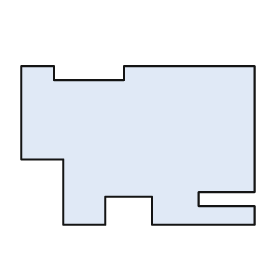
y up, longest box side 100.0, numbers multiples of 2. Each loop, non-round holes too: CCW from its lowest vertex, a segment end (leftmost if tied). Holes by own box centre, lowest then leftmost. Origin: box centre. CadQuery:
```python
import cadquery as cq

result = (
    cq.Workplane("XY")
    .moveTo(-32.0, -34.0)
    .lineTo(-14.0, -34.0)
    .lineTo(-14.0, -22.0)
    .lineTo(6.0, -22.0)
    .lineTo(6.0, -34.0)
    .lineTo(50.0, -34.0)
    .lineTo(50.0, -26.0)
    .lineTo(26.0, -26.0)
    .lineTo(26.0, -20.0)
    .lineTo(50.0, -20.0)
    .lineTo(50.0, 34.0)
    .lineTo(-6.0, 34.0)
    .lineTo(-6.0, 28.0)
    .lineTo(-36.0, 28.0)
    .lineTo(-36.0, 34.0)
    .lineTo(-50.0, 34.0)
    .lineTo(-50.0, -6.0)
    .lineTo(-32.0, -6.0)
    .close()
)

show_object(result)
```